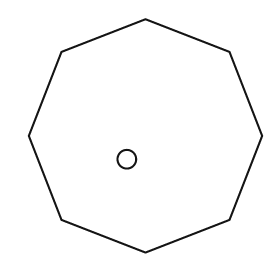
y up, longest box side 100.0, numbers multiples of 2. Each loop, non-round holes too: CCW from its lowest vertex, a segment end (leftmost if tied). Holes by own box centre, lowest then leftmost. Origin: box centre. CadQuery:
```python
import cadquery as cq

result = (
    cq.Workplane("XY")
    .moveTo(0.0, -50.0)
    .lineTo(36.0, -36.0)
    .lineTo(50.0, 0.0)
    .lineTo(36.0, 36.0)
    .lineTo(0.0, 50.0)
    .lineTo(-36.0, 36.0)
    .lineTo(-50.0, 0.0)
    .lineTo(-36.0, -36.0)
    .close()
    .moveTo(-8.0, -10.0)
    .circle(4.0)
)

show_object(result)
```